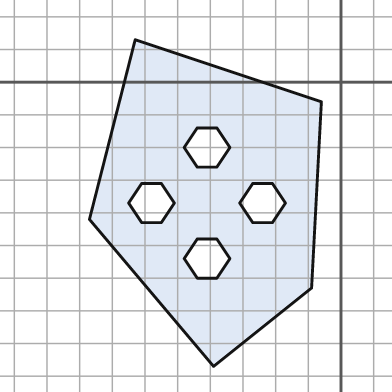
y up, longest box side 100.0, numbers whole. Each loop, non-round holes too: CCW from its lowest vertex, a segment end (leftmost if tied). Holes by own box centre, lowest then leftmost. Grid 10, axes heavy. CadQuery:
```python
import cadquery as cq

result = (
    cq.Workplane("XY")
    .moveTo(-39.0, -87.0)
    .lineTo(-9.0, -63.0)
    .lineTo(-6.0, -6.0)
    .lineTo(-63.0, 13.0)
    .lineTo(-77.0, -42.0)
    .close()
    .moveTo(-44.0, -60.0)
    .lineTo(-38.0, -60.0)
    .lineTo(-34.0, -54.0)
    .lineTo(-38.0, -48.0)
    .lineTo(-44.0, -48.0)
    .lineTo(-48.0, -54.0)
    .close()
    .moveTo(-61.0, -43.0)
    .lineTo(-55.0, -43.0)
    .lineTo(-51.0, -37.0)
    .lineTo(-55.0, -31.0)
    .lineTo(-61.0, -31.0)
    .lineTo(-65.0, -37.0)
    .close()
    .moveTo(-27.0, -43.0)
    .lineTo(-21.0, -43.0)
    .lineTo(-17.0, -37.0)
    .lineTo(-21.0, -31.0)
    .lineTo(-27.0, -31.0)
    .lineTo(-31.0, -37.0)
    .close()
    .moveTo(-44.0, -26.0)
    .lineTo(-38.0, -26.0)
    .lineTo(-34.0, -20.0)
    .lineTo(-38.0, -14.0)
    .lineTo(-44.0, -14.0)
    .lineTo(-48.0, -20.0)
    .close()
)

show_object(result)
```